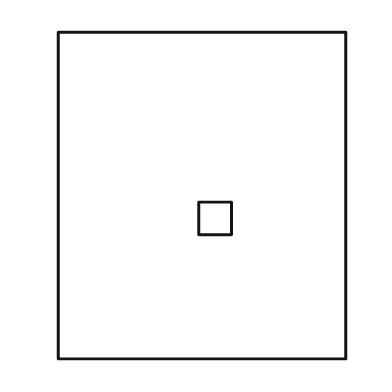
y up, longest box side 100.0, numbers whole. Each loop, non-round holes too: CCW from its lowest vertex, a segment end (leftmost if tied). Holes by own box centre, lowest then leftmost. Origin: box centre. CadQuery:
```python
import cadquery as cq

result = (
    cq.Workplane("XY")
    .moveTo(-44.0, -50.0)
    .lineTo(44.0, -50.0)
    .lineTo(44.0, 50.0)
    .lineTo(-44.0, 50.0)
    .close()
    .moveTo(-1.0, -12.0)
    .lineTo(9.0, -12.0)
    .lineTo(9.0, -2.0)
    .lineTo(-1.0, -2.0)
    .close()
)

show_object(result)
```